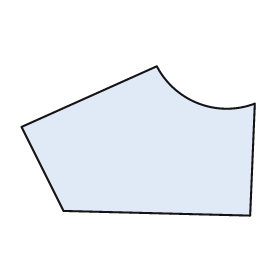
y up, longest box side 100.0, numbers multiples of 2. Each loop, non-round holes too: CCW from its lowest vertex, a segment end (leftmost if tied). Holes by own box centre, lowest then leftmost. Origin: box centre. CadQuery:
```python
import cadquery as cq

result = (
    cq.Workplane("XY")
    .moveTo(48.0, -32.0)
    .lineTo(50.0, 16.0)
    .threePointArc((26.0, 16.0), (8.0, 32.0))
    .lineTo(-50.0, 6.0)
    .lineTo(-32.0, -30.0)
    .close()
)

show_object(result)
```